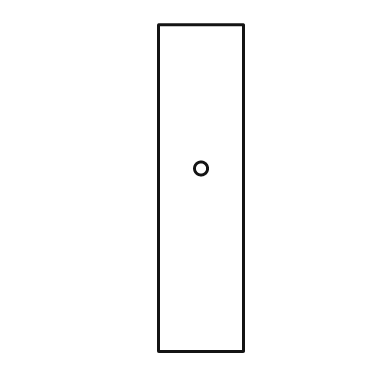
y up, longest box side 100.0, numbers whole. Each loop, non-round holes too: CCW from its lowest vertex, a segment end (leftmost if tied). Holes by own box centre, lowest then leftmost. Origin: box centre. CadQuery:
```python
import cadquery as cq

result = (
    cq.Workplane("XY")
    .moveTo(-13.0, -50.0)
    .lineTo(13.0, -50.0)
    .lineTo(13.0, 50.0)
    .lineTo(-13.0, 50.0)
    .close()
    .moveTo(0.0, 6.0)
    .circle(2.0)
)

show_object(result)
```